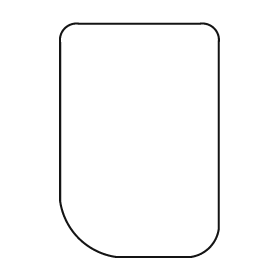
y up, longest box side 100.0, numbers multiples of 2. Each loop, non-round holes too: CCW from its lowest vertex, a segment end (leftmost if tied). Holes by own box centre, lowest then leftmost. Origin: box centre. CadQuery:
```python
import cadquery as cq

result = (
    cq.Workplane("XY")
    .moveTo(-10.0, -50.0)
    .lineTo(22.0, -50.0)
    .threePointArc((30.0, -46.0), (34.0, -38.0))
    .lineTo(34.0, 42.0)
    .threePointArc((32.0, 48.0), (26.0, 50.0))
    .lineTo(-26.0, 50.0)
    .threePointArc((-32.0, 48.0), (-34.0, 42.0))
    .lineTo(-34.0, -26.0)
    .threePointArc((-26.0, -42.0), (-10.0, -50.0))
    .close()
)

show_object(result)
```